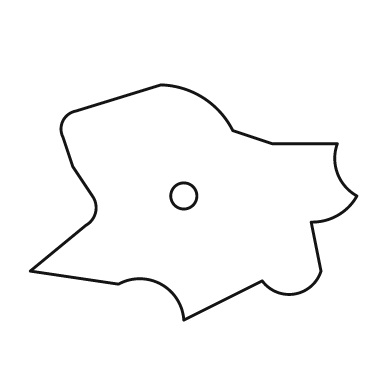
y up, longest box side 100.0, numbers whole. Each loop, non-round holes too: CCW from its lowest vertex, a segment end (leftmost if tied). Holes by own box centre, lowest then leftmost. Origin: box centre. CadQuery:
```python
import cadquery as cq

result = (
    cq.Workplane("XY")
    .moveTo(-3.0, -36.0)
    .lineTo(21.0, -24.0)
    .threePointArc((31.0, -28.0), (39.0, -21.0))
    .lineTo(36.0, -6.0)
    .threePointArc((44.0, -4.0), (50.0, 2.0))
    .threePointArc((44.0, 9.0), (44.0, 18.0))
    .lineTo(24.0, 18.0)
    .lineTo(12.0, 22.0)
    .threePointArc((3.0, 32.0), (-10.0, 36.0))
    .lineTo(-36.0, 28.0)
    .threePointArc((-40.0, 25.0), (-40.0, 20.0))
    .lineTo(-37.0, 11.0)
    .lineTo(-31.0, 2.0)
    .threePointArc((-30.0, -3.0), (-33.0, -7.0))
    .lineTo(-50.0, -21.0)
    .lineTo(-23.0, -25.0)
    .threePointArc((-10.0, -25.0), (-3.0, -36.0))
    .close()
    .moveTo(-3.0, 2.0)
    .circle(4.0)
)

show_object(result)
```